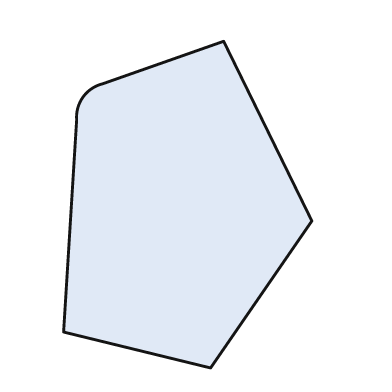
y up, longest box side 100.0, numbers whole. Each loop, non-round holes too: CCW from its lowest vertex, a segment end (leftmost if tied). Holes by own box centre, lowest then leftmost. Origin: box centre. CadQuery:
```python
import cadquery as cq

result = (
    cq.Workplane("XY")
    .moveTo(7.0, -50.0)
    .lineTo(38.0, -5.0)
    .lineTo(11.0, 50.0)
    .lineTo(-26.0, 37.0)
    .threePointArc((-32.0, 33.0), (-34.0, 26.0))
    .lineTo(-38.0, -39.0)
    .close()
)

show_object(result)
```